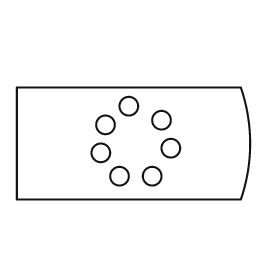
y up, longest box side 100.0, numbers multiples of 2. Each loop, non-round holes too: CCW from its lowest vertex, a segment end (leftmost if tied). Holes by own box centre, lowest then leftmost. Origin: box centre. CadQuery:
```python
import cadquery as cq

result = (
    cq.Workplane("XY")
    .moveTo(-50.0, -24.0)
    .lineTo(46.0, -24.0)
    .threePointArc((50.0, 0.0), (46.0, 24.0))
    .lineTo(-50.0, 24.0)
    .close()
    .moveTo(-6.0, -14.0)
    .circle(4.0)
    .moveTo(8.0, -14.0)
    .circle(4.0)
    .moveTo(-14.0, -4.0)
    .circle(4.0)
    .moveTo(16.0, -2.0)
    .circle(4.0)
    .moveTo(-12.0, 8.0)
    .circle(4.0)
    .moveTo(12.0, 10.0)
    .circle(4.0)
    .moveTo(-2.0, 16.0)
    .circle(4.0)
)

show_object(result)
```